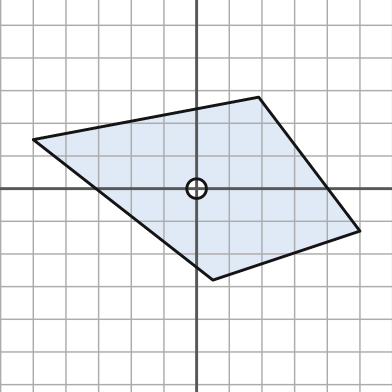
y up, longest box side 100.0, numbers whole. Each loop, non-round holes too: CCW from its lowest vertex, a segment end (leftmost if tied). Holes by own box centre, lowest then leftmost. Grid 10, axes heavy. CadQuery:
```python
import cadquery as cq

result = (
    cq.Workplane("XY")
    .moveTo(5.0, -28.0)
    .lineTo(50.0, -13.0)
    .lineTo(19.0, 28.0)
    .lineTo(-50.0, 15.0)
    .close()
    .moveTo(0.0, 0.0)
    .circle(3.0)
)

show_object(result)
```